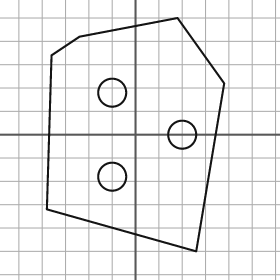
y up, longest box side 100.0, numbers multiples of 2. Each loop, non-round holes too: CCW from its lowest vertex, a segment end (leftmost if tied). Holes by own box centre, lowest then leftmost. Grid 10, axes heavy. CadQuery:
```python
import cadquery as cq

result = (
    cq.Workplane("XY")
    .moveTo(26.0, -50.0)
    .lineTo(38.0, 22.0)
    .lineTo(18.0, 50.0)
    .lineTo(-24.0, 42.0)
    .lineTo(-36.0, 34.0)
    .lineTo(-38.0, -32.0)
    .close()
    .moveTo(-10.0, -18.0)
    .circle(6.0)
    .moveTo(20.0, 0.0)
    .circle(6.0)
    .moveTo(-10.0, 18.0)
    .circle(6.0)
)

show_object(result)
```